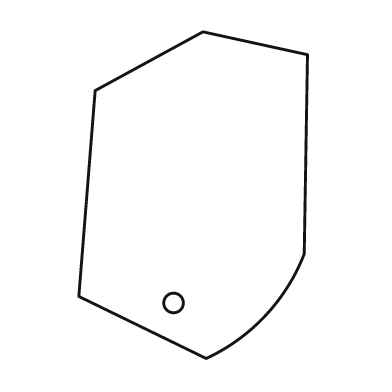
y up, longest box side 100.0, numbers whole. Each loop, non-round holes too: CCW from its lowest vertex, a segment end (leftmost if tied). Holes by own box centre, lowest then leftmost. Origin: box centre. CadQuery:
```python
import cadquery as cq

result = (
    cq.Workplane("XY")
    .moveTo(4.0, -50.0)
    .threePointArc((22.0, -37.0), (34.0, -18.0))
    .lineTo(35.0, 43.0)
    .lineTo(3.0, 50.0)
    .lineTo(-30.0, 32.0)
    .lineTo(-35.0, -31.0)
    .close()
    .moveTo(-6.0, -33.0)
    .circle(3.0)
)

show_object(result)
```